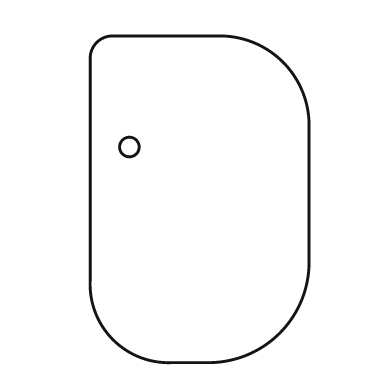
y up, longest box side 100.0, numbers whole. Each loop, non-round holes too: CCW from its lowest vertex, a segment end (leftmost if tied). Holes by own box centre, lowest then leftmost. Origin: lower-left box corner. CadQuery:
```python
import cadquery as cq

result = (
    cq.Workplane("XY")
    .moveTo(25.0, 0.0)
    .lineTo(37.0, 0.0)
    .threePointArc((58.0, 9.0), (67.0, 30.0))
    .lineTo(67.0, 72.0)
    .threePointArc((59.0, 92.0), (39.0, 100.0))
    .lineTo(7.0, 100.0)
    .threePointArc((2.0, 98.0), (0.0, 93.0))
    .lineTo(0.0, 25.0)
    .threePointArc((7.0, 7.0), (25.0, 0.0))
    .close()
    .moveTo(12.0, 66.0)
    .circle(3.0)
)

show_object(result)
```